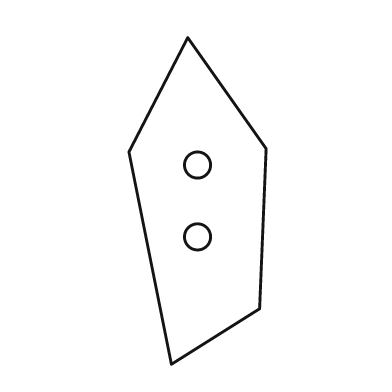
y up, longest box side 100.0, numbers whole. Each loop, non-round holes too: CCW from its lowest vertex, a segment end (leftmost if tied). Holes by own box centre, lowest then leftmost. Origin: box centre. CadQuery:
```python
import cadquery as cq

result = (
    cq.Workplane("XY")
    .moveTo(-8.0, -50.0)
    .lineTo(19.0, -33.0)
    .lineTo(21.0, 16.0)
    .lineTo(-3.0, 50.0)
    .lineTo(-21.0, 15.0)
    .close()
    .moveTo(0.0, -11.0)
    .circle(4.0)
    .moveTo(0.0, 11.0)
    .circle(4.0)
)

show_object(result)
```